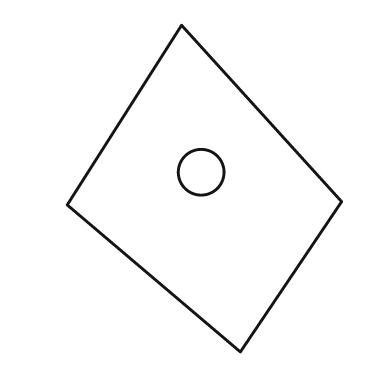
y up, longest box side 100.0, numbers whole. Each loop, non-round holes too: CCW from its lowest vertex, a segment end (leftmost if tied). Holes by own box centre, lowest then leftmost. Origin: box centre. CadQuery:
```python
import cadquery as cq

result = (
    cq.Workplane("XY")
    .moveTo(11.0, -50.0)
    .lineTo(42.0, -4.0)
    .lineTo(-7.0, 50.0)
    .lineTo(-42.0, -5.0)
    .close()
    .moveTo(-1.0, 5.0)
    .circle(7.0)
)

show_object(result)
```